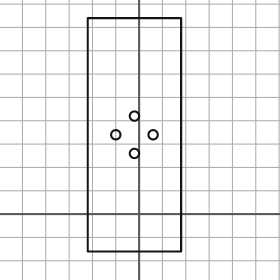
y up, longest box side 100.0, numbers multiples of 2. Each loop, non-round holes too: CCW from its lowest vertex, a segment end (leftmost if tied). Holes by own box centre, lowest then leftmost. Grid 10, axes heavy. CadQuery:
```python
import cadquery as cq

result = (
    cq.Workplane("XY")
    .moveTo(-22.0, -16.0)
    .lineTo(18.0, -16.0)
    .lineTo(18.0, 84.0)
    .lineTo(-22.0, 84.0)
    .close()
    .moveTo(-2.0, 26.0)
    .circle(2.0)
    .moveTo(-10.0, 34.0)
    .circle(2.0)
    .moveTo(6.0, 34.0)
    .circle(2.0)
    .moveTo(-2.0, 42.0)
    .circle(2.0)
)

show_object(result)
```